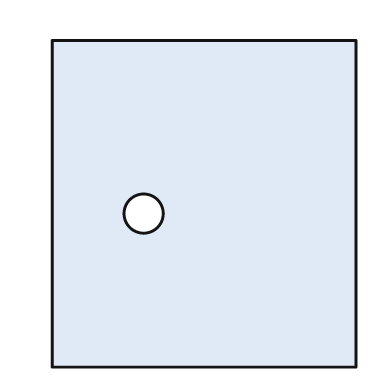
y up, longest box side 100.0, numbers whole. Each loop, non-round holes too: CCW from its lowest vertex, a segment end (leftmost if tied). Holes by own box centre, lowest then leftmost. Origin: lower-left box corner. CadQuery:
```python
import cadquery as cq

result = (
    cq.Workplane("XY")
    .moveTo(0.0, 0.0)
    .lineTo(93.0, 0.0)
    .lineTo(93.0, 100.0)
    .lineTo(0.0, 100.0)
    .close()
    .moveTo(28.0, 47.0)
    .circle(6.0)
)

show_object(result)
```